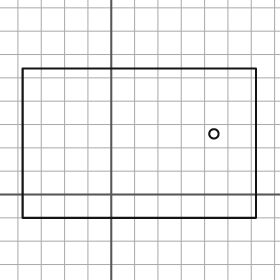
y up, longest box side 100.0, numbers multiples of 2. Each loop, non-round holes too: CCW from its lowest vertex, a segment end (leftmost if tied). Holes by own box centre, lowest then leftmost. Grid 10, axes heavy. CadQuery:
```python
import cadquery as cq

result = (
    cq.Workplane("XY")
    .moveTo(-38.0, -10.0)
    .lineTo(62.0, -10.0)
    .lineTo(62.0, 54.0)
    .lineTo(-38.0, 54.0)
    .close()
    .moveTo(44.0, 26.0)
    .circle(2.0)
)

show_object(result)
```